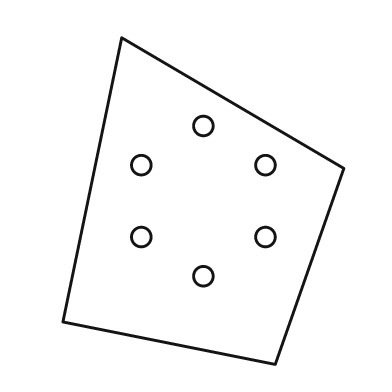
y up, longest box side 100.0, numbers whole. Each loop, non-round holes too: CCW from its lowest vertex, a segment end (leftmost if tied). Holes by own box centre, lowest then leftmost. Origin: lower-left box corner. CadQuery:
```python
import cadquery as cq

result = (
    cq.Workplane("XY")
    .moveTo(65.0, 0.0)
    .lineTo(86.0, 60.0)
    .lineTo(18.0, 100.0)
    .lineTo(0.0, 13.0)
    .close()
    .moveTo(43.0, 27.0)
    .circle(3.0)
    .moveTo(24.0, 39.0)
    .circle(3.0)
    .moveTo(62.0, 39.0)
    .circle(3.0)
    .moveTo(24.0, 61.0)
    .circle(3.0)
    .moveTo(62.0, 61.0)
    .circle(3.0)
    .moveTo(43.0, 73.0)
    .circle(3.0)
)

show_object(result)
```